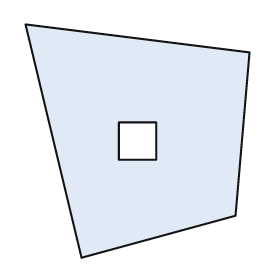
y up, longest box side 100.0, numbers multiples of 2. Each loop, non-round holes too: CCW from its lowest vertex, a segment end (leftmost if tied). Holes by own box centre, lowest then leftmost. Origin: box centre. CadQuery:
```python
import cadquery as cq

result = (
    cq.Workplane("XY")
    .moveTo(-24.0, -50.0)
    .lineTo(42.0, -32.0)
    .lineTo(48.0, 38.0)
    .lineTo(-48.0, 50.0)
    .close()
    .moveTo(-8.0, -8.0)
    .lineTo(8.0, -8.0)
    .lineTo(8.0, 8.0)
    .lineTo(-8.0, 8.0)
    .close()
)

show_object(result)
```